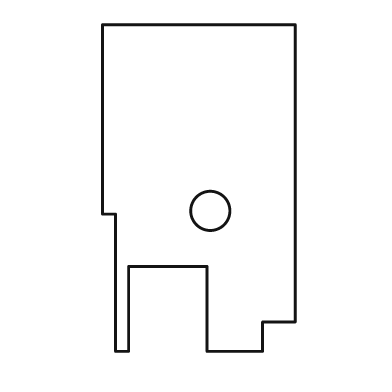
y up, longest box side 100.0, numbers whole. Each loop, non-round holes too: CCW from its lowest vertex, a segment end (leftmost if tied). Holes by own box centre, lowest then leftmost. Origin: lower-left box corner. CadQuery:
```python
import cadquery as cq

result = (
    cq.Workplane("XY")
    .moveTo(4.0, 0.0)
    .lineTo(8.0, 0.0)
    .lineTo(8.0, 26.0)
    .lineTo(32.0, 26.0)
    .lineTo(32.0, 0.0)
    .lineTo(49.0, 0.0)
    .lineTo(49.0, 9.0)
    .lineTo(59.0, 9.0)
    .lineTo(59.0, 100.0)
    .lineTo(0.0, 100.0)
    .lineTo(0.0, 42.0)
    .lineTo(4.0, 42.0)
    .close()
    .moveTo(33.0, 43.0)
    .circle(6.0)
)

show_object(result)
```